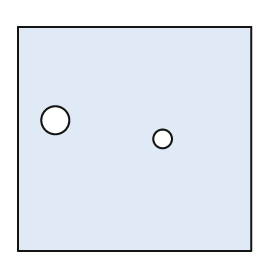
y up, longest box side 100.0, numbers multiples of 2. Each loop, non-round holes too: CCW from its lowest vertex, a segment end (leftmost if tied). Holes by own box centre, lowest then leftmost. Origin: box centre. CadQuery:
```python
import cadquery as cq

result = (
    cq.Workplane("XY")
    .moveTo(-50.0, -48.0)
    .lineTo(50.0, -48.0)
    .lineTo(50.0, 48.0)
    .lineTo(-50.0, 48.0)
    .close()
    .moveTo(12.0, 0.0)
    .circle(4.0)
    .moveTo(-34.0, 8.0)
    .circle(6.0)
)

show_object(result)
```